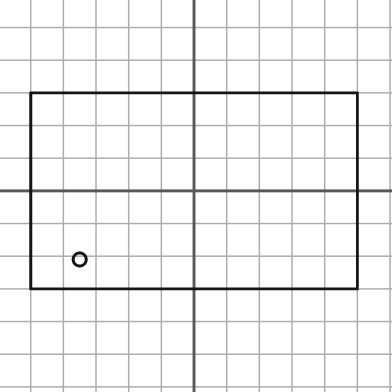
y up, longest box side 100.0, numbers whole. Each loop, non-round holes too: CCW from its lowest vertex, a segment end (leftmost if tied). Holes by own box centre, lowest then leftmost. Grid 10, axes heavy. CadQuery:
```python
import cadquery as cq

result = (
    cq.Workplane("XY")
    .moveTo(-50.0, -30.0)
    .lineTo(50.0, -30.0)
    .lineTo(50.0, 30.0)
    .lineTo(-50.0, 30.0)
    .close()
    .moveTo(-35.0, -21.0)
    .circle(2.0)
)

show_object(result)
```